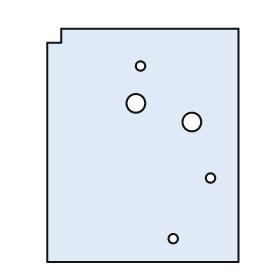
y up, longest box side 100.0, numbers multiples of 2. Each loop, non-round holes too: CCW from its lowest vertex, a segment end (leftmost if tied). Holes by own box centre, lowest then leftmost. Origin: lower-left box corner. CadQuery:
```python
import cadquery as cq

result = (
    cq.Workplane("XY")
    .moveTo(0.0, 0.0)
    .lineTo(82.0, 0.0)
    .lineTo(82.0, 100.0)
    .lineTo(6.0, 100.0)
    .lineTo(6.0, 94.0)
    .lineTo(0.0, 94.0)
    .close()
    .moveTo(54.0, 10.0)
    .circle(2.0)
    .moveTo(70.0, 36.0)
    .circle(2.0)
    .moveTo(62.0, 60.0)
    .circle(4.0)
    .moveTo(38.0, 68.0)
    .circle(4.0)
    .moveTo(40.0, 84.0)
    .circle(2.0)
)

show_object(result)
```